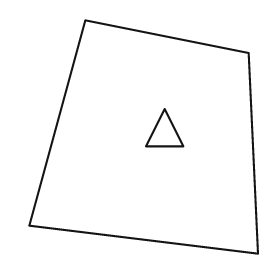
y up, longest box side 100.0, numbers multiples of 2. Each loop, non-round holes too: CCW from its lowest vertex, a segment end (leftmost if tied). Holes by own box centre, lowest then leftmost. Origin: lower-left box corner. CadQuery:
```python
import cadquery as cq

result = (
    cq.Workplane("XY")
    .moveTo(98.0, 0.0)
    .lineTo(94.0, 86.0)
    .lineTo(24.0, 100.0)
    .lineTo(0.0, 12.0)
    .close()
    .moveTo(50.0, 46.0)
    .lineTo(66.0, 46.0)
    .lineTo(58.0, 62.0)
    .close()
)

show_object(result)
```